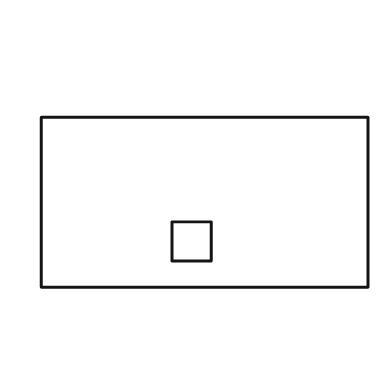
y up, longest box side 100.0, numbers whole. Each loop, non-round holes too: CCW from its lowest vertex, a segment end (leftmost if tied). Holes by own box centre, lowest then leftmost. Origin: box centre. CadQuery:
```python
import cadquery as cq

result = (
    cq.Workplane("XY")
    .moveTo(-50.0, -26.0)
    .lineTo(50.0, -26.0)
    .lineTo(50.0, 26.0)
    .lineTo(-50.0, 26.0)
    .close()
    .moveTo(-10.0, -18.0)
    .lineTo(2.0, -18.0)
    .lineTo(2.0, -6.0)
    .lineTo(-10.0, -6.0)
    .close()
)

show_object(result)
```